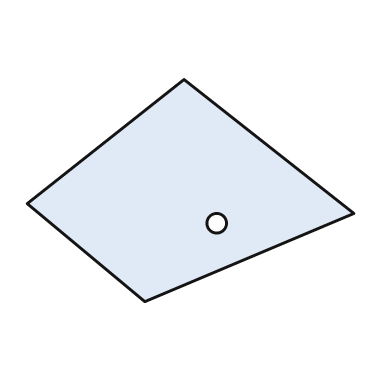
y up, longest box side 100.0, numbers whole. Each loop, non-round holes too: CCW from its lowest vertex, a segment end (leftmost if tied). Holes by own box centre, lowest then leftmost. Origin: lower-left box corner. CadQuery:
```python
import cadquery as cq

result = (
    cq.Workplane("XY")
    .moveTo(36.0, 0.0)
    .lineTo(100.0, 27.0)
    .lineTo(48.0, 68.0)
    .lineTo(0.0, 30.0)
    .close()
    .moveTo(58.0, 24.0)
    .circle(3.0)
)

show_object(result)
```